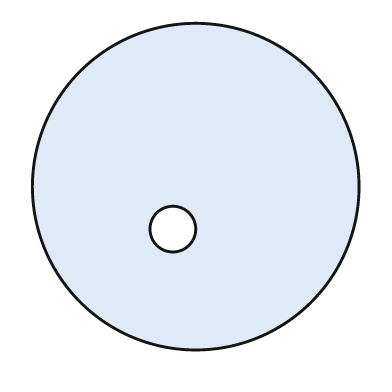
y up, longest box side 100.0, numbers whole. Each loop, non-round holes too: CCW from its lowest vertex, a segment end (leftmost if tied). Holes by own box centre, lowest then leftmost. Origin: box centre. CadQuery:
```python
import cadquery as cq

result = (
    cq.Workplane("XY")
    .moveTo(0.0, 0.0)
    .circle(50.0)
    .moveTo(-7.0, -13.0)
    .circle(7.0)
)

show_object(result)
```